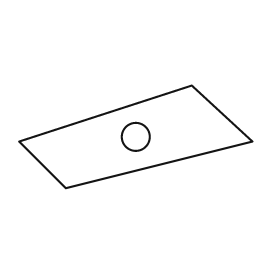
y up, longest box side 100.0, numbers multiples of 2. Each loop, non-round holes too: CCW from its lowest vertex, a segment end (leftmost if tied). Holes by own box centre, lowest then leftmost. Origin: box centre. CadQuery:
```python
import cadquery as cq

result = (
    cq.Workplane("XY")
    .moveTo(-30.0, -22.0)
    .lineTo(50.0, -2.0)
    .lineTo(24.0, 22.0)
    .lineTo(-50.0, -2.0)
    .close()
    .moveTo(0.0, 0.0)
    .circle(6.0)
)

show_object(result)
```